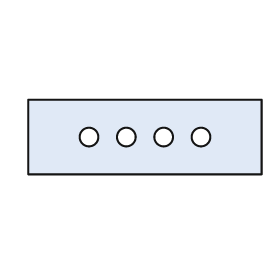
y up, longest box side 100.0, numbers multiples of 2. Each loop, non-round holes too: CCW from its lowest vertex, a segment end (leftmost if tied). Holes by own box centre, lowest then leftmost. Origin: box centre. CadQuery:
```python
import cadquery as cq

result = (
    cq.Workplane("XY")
    .moveTo(-50.0, -16.0)
    .lineTo(50.0, -16.0)
    .lineTo(50.0, 16.0)
    .lineTo(-50.0, 16.0)
    .close()
    .moveTo(-24.0, 0.0)
    .circle(4.0)
    .moveTo(-8.0, 0.0)
    .circle(4.0)
    .moveTo(8.0, 0.0)
    .circle(4.0)
    .moveTo(24.0, 0.0)
    .circle(4.0)
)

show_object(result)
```